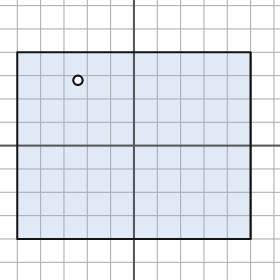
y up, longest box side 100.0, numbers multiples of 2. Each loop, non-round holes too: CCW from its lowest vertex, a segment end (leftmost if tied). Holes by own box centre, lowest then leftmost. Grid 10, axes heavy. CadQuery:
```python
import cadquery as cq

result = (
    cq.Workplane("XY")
    .moveTo(-50.0, -40.0)
    .lineTo(50.0, -40.0)
    .lineTo(50.0, 40.0)
    .lineTo(-50.0, 40.0)
    .close()
    .moveTo(-24.0, 28.0)
    .circle(2.0)
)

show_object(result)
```